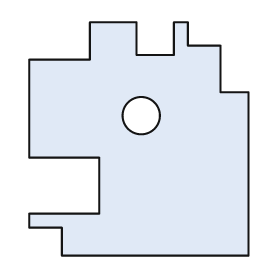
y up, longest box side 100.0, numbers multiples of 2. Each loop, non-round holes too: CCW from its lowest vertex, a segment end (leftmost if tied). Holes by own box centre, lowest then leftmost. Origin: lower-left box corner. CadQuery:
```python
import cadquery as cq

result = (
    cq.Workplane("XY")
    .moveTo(14.0, 0.0)
    .lineTo(94.0, 0.0)
    .lineTo(94.0, 70.0)
    .lineTo(82.0, 70.0)
    .lineTo(82.0, 90.0)
    .lineTo(68.0, 90.0)
    .lineTo(68.0, 100.0)
    .lineTo(62.0, 100.0)
    .lineTo(62.0, 86.0)
    .lineTo(46.0, 86.0)
    .lineTo(46.0, 100.0)
    .lineTo(26.0, 100.0)
    .lineTo(26.0, 84.0)
    .lineTo(0.0, 84.0)
    .lineTo(0.0, 42.0)
    .lineTo(30.0, 42.0)
    .lineTo(30.0, 18.0)
    .lineTo(0.0, 18.0)
    .lineTo(0.0, 12.0)
    .lineTo(14.0, 12.0)
    .close()
    .moveTo(48.0, 60.0)
    .circle(8.0)
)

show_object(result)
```